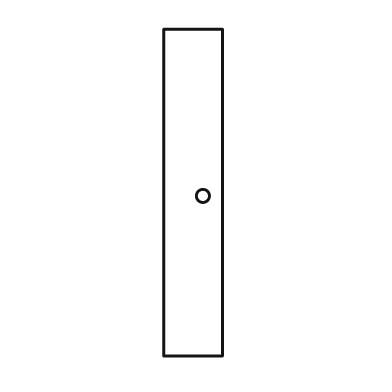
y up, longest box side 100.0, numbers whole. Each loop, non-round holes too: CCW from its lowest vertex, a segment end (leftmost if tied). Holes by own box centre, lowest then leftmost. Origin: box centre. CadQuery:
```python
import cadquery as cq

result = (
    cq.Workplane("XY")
    .moveTo(-9.0, -50.0)
    .lineTo(9.0, -50.0)
    .lineTo(9.0, 50.0)
    .lineTo(-9.0, 50.0)
    .close()
    .moveTo(3.0, -1.0)
    .circle(2.0)
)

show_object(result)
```